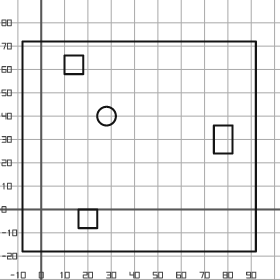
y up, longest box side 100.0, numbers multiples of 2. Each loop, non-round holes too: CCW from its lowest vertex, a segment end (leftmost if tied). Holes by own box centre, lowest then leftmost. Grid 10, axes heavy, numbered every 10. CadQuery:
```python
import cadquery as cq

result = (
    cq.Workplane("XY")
    .moveTo(-8.0, -18.0)
    .lineTo(92.0, -18.0)
    .lineTo(92.0, 72.0)
    .lineTo(-8.0, 72.0)
    .close()
    .moveTo(16.0, -8.0)
    .lineTo(24.0, -8.0)
    .lineTo(24.0, 0.0)
    .lineTo(16.0, 0.0)
    .close()
    .moveTo(74.0, 24.0)
    .lineTo(82.0, 24.0)
    .lineTo(82.0, 36.0)
    .lineTo(74.0, 36.0)
    .close()
    .moveTo(28.0, 40.0)
    .circle(4.0)
    .moveTo(10.0, 58.0)
    .lineTo(18.0, 58.0)
    .lineTo(18.0, 66.0)
    .lineTo(10.0, 66.0)
    .close()
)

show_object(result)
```